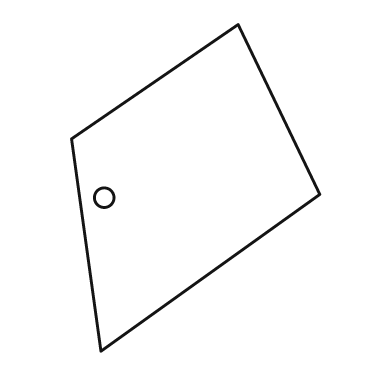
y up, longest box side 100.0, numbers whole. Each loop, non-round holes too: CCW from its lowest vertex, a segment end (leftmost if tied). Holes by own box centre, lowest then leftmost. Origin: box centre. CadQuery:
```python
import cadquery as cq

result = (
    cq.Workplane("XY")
    .moveTo(-29.0, -50.0)
    .lineTo(38.0, -2.0)
    .lineTo(13.0, 50.0)
    .lineTo(-38.0, 15.0)
    .close()
    .moveTo(-28.0, -3.0)
    .circle(3.0)
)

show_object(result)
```